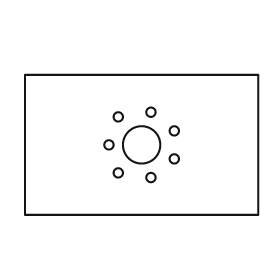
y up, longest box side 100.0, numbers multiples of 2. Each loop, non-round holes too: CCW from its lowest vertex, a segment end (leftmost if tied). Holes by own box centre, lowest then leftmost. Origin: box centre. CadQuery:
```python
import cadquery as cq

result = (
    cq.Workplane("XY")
    .moveTo(-50.0, -30.0)
    .lineTo(50.0, -30.0)
    .lineTo(50.0, 30.0)
    .lineTo(-50.0, 30.0)
    .close()
    .moveTo(4.0, -14.0)
    .circle(2.0)
    .moveTo(-10.0, -12.0)
    .circle(2.0)
    .moveTo(14.0, -6.0)
    .circle(2.0)
    .moveTo(-14.0, 0.0)
    .circle(2.0)
    .moveTo(0.0, 0.0)
    .circle(8.0)
    .moveTo(14.0, 6.0)
    .circle(2.0)
    .moveTo(-10.0, 12.0)
    .circle(2.0)
    .moveTo(4.0, 14.0)
    .circle(2.0)
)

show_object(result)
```